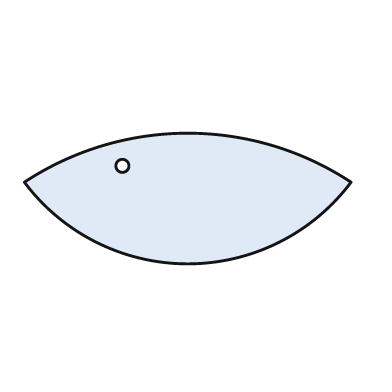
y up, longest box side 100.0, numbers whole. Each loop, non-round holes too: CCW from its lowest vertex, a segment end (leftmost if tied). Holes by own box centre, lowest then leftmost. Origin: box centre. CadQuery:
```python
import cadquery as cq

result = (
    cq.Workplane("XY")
    .moveTo(-50.0, 5.0)
    .threePointArc((0.0, -20.0), (50.0, 5.0))
    .threePointArc((0.0, 20.0), (-50.0, 5.0))
    .close()
    .moveTo(-20.0, 10.0)
    .circle(2.0)
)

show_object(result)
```